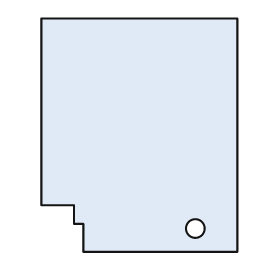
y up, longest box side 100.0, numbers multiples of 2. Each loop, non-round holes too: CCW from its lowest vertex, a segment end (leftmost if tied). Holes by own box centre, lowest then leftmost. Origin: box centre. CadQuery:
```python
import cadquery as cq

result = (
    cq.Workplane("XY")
    .moveTo(-24.0, -50.0)
    .lineTo(42.0, -50.0)
    .lineTo(42.0, 50.0)
    .lineTo(-42.0, 50.0)
    .lineTo(-42.0, -30.0)
    .lineTo(-28.0, -30.0)
    .lineTo(-28.0, -38.0)
    .lineTo(-24.0, -38.0)
    .close()
    .moveTo(24.0, -40.0)
    .circle(4.0)
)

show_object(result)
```